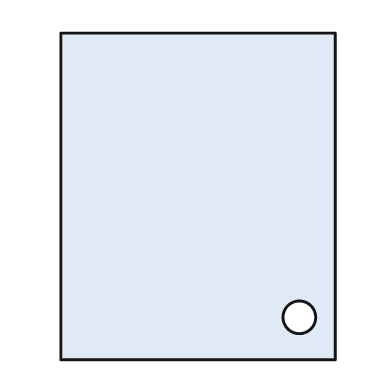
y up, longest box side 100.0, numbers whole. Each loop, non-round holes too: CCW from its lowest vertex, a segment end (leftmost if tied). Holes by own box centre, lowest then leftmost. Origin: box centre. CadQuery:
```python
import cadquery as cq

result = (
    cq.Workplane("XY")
    .moveTo(-42.0, -50.0)
    .lineTo(42.0, -50.0)
    .lineTo(42.0, 50.0)
    .lineTo(-42.0, 50.0)
    .close()
    .moveTo(31.0, -37.0)
    .circle(5.0)
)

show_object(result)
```